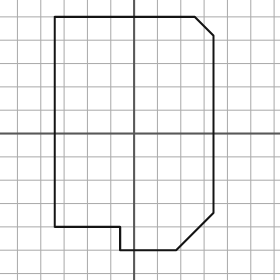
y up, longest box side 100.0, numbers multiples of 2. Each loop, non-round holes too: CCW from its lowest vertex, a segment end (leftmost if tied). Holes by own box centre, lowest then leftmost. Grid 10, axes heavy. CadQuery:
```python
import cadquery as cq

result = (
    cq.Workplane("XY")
    .moveTo(-6.0, -50.0)
    .lineTo(18.0, -50.0)
    .lineTo(34.0, -34.0)
    .lineTo(34.0, 42.0)
    .lineTo(26.0, 50.0)
    .lineTo(-34.0, 50.0)
    .lineTo(-34.0, -40.0)
    .lineTo(-6.0, -40.0)
    .close()
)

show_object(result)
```